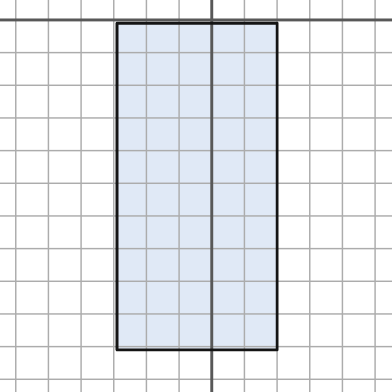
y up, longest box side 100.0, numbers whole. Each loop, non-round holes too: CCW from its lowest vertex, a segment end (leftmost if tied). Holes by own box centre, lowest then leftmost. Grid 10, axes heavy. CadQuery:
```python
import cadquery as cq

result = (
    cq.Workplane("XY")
    .moveTo(-29.0, -101.0)
    .lineTo(20.0, -101.0)
    .lineTo(20.0, -1.0)
    .lineTo(-29.0, -1.0)
    .close()
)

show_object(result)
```